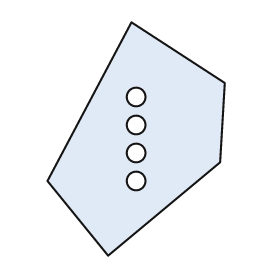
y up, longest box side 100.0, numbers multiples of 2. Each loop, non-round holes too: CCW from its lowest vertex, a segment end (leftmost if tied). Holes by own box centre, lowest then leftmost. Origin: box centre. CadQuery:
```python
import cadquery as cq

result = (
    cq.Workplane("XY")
    .moveTo(-12.0, -50.0)
    .lineTo(36.0, -10.0)
    .lineTo(38.0, 24.0)
    .lineTo(-2.0, 50.0)
    .lineTo(-38.0, -18.0)
    .close()
    .moveTo(0.0, -18.0)
    .circle(4.0)
    .moveTo(0.0, -6.0)
    .circle(4.0)
    .moveTo(0.0, 6.0)
    .circle(4.0)
    .moveTo(0.0, 18.0)
    .circle(4.0)
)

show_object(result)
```